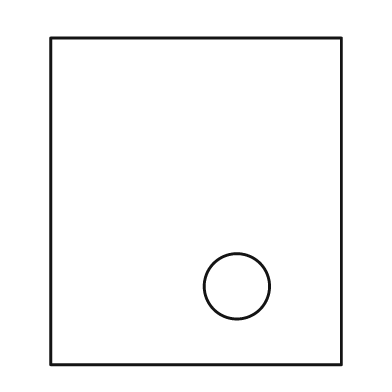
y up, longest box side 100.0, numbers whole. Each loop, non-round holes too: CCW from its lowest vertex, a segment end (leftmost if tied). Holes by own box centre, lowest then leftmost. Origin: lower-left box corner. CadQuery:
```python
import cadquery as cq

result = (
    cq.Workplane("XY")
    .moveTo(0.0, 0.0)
    .lineTo(89.0, 0.0)
    .lineTo(89.0, 100.0)
    .lineTo(0.0, 100.0)
    .close()
    .moveTo(57.0, 24.0)
    .circle(10.0)
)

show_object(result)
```